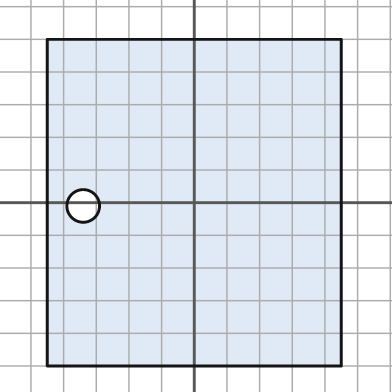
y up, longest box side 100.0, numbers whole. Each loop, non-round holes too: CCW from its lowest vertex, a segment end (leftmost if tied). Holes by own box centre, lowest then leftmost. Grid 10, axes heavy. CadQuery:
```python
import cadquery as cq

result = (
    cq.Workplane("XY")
    .moveTo(-45.0, -50.0)
    .lineTo(45.0, -50.0)
    .lineTo(45.0, 50.0)
    .lineTo(-45.0, 50.0)
    .close()
    .moveTo(-34.0, -1.0)
    .circle(5.0)
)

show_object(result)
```